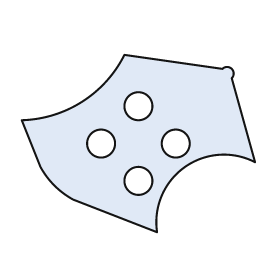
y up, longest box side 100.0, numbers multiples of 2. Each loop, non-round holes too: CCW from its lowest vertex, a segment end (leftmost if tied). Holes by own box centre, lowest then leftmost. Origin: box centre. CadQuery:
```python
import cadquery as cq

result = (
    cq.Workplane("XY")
    .moveTo(8.0, -38.0)
    .threePointArc((20.0, -10.0), (50.0, -8.0))
    .lineTo(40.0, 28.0)
    .threePointArc((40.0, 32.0), (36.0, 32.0))
    .lineTo(-6.0, 38.0)
    .threePointArc((-24.0, 18.0), (-50.0, 10.0))
    .lineTo(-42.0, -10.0)
    .threePointArc((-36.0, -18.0), (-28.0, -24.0))
    .close()
    .moveTo(0.0, -16.0)
    .circle(6.0)
    .moveTo(-16.0, 0.0)
    .circle(6.0)
    .moveTo(16.0, 0.0)
    .circle(6.0)
    .moveTo(0.0, 16.0)
    .circle(6.0)
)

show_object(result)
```